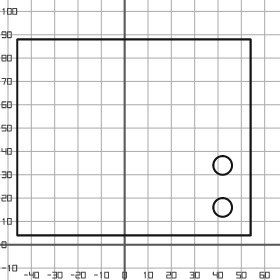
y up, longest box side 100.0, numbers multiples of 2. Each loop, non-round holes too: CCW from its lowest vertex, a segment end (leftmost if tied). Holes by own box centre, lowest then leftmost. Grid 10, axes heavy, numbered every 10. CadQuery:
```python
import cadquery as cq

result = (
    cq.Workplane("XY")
    .moveTo(-46.0, 4.0)
    .lineTo(54.0, 4.0)
    .lineTo(54.0, 88.0)
    .lineTo(-46.0, 88.0)
    .close()
    .moveTo(42.0, 16.0)
    .circle(4.0)
    .moveTo(42.0, 34.0)
    .circle(4.0)
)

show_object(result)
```